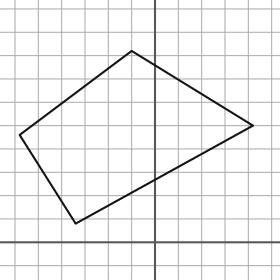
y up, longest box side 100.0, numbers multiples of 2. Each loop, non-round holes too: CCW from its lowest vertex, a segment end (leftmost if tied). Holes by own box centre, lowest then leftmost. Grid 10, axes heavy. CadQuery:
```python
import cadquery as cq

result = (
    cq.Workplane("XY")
    .moveTo(-34.0, 8.0)
    .lineTo(42.0, 50.0)
    .lineTo(-10.0, 82.0)
    .lineTo(-58.0, 46.0)
    .close()
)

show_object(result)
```